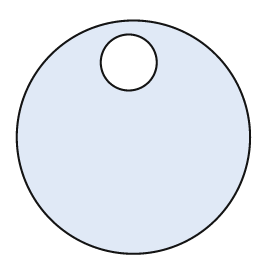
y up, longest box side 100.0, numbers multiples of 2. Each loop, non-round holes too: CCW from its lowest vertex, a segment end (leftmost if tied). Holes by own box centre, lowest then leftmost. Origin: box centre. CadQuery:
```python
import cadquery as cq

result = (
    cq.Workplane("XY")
    .moveTo(0.0, 0.0)
    .circle(50.0)
    .moveTo(-2.0, 32.0)
    .circle(12.0)
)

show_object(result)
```